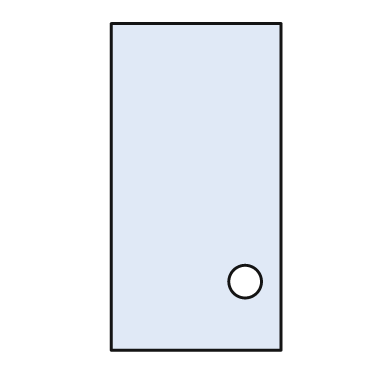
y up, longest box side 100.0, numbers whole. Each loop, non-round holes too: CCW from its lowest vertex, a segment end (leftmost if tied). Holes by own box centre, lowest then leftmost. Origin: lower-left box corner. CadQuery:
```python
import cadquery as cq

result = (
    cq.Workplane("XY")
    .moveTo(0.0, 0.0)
    .lineTo(52.0, 0.0)
    .lineTo(52.0, 100.0)
    .lineTo(0.0, 100.0)
    .close()
    .moveTo(41.0, 21.0)
    .circle(5.0)
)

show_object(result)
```